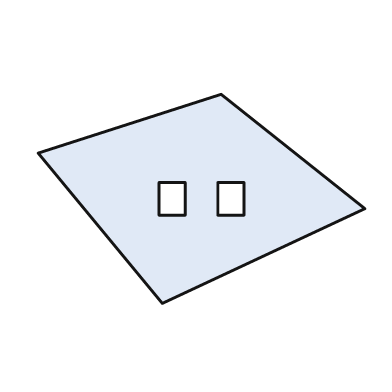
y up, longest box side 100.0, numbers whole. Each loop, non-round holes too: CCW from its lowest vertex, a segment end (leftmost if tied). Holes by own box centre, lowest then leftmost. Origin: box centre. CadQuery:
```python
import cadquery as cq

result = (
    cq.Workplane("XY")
    .moveTo(-12.0, -32.0)
    .lineTo(50.0, -3.0)
    .lineTo(6.0, 32.0)
    .lineTo(-50.0, 14.0)
    .close()
    .moveTo(-13.0, -5.0)
    .lineTo(-5.0, -5.0)
    .lineTo(-5.0, 5.0)
    .lineTo(-13.0, 5.0)
    .close()
    .moveTo(5.0, -5.0)
    .lineTo(13.0, -5.0)
    .lineTo(13.0, 5.0)
    .lineTo(5.0, 5.0)
    .close()
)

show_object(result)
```